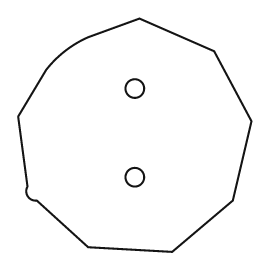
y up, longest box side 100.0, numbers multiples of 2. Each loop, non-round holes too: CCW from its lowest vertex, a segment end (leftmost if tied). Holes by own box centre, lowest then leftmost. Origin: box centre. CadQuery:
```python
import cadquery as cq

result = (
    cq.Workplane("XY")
    .moveTo(16.0, -50.0)
    .lineTo(42.0, -28.0)
    .lineTo(50.0, 6.0)
    .lineTo(34.0, 36.0)
    .lineTo(2.0, 50.0)
    .lineTo(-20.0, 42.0)
    .threePointArc((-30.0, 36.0), (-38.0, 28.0))
    .lineTo(-50.0, 8.0)
    .lineTo(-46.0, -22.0)
    .threePointArc((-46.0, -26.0), (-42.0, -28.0))
    .lineTo(-20.0, -48.0)
    .close()
    .moveTo(0.0, -18.0)
    .circle(4.0)
    .moveTo(0.0, 20.0)
    .circle(4.0)
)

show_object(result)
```